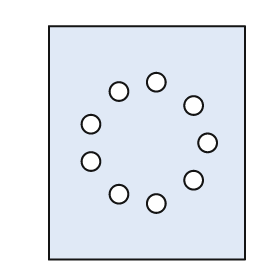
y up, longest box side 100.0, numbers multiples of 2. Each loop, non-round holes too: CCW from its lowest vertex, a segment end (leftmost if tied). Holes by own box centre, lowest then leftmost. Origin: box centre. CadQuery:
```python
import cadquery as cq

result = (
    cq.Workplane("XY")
    .moveTo(-42.0, -50.0)
    .lineTo(42.0, -50.0)
    .lineTo(42.0, 50.0)
    .lineTo(-42.0, 50.0)
    .close()
    .moveTo(4.0, -26.0)
    .circle(4.0)
    .moveTo(-12.0, -22.0)
    .circle(4.0)
    .moveTo(20.0, -16.0)
    .circle(4.0)
    .moveTo(-24.0, -8.0)
    .circle(4.0)
    .moveTo(26.0, 0.0)
    .circle(4.0)
    .moveTo(-24.0, 8.0)
    .circle(4.0)
    .moveTo(20.0, 16.0)
    .circle(4.0)
    .moveTo(-12.0, 22.0)
    .circle(4.0)
    .moveTo(4.0, 26.0)
    .circle(4.0)
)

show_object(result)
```